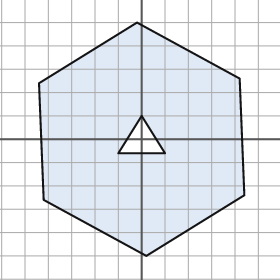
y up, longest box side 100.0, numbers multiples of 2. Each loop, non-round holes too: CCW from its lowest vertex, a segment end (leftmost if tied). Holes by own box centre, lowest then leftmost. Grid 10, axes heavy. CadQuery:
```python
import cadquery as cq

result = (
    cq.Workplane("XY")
    .moveTo(2.0, -50.0)
    .lineTo(44.0, -24.0)
    .lineTo(42.0, 26.0)
    .lineTo(-2.0, 50.0)
    .lineTo(-44.0, 24.0)
    .lineTo(-42.0, -26.0)
    .close()
    .moveTo(-10.0, -6.0)
    .lineTo(10.0, -6.0)
    .lineTo(0.0, 10.0)
    .close()
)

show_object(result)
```